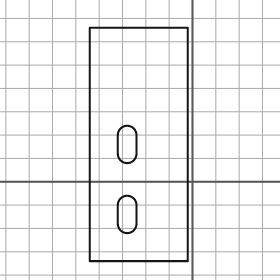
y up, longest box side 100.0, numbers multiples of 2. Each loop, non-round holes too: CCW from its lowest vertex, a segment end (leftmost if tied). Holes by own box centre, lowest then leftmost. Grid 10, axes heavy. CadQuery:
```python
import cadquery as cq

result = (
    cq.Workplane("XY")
    .moveTo(-44.0, -34.0)
    .lineTo(-2.0, -34.0)
    .lineTo(-2.0, 66.0)
    .lineTo(-44.0, 66.0)
    .close()
    .moveTo(-32.0, -18.0)
    .threePointArc((-28.0, -22.0), (-24.0, -18.0))
    .lineTo(-24.0, -10.0)
    .threePointArc((-28.0, -6.0), (-32.0, -10.0))
    .close()
    .moveTo(-32.0, 12.0)
    .threePointArc((-28.0, 8.0), (-24.0, 12.0))
    .lineTo(-24.0, 20.0)
    .threePointArc((-28.0, 24.0), (-32.0, 20.0))
    .close()
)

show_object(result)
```